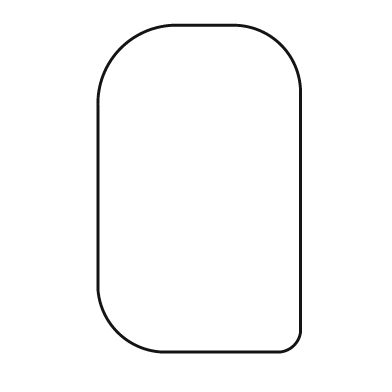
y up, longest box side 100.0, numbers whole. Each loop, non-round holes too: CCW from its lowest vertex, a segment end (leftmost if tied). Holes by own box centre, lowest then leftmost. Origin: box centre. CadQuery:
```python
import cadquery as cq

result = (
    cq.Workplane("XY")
    .moveTo(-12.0, -50.0)
    .lineTo(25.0, -50.0)
    .threePointArc((29.0, -48.0), (31.0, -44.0))
    .lineTo(31.0, 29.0)
    .threePointArc((25.0, 44.0), (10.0, 50.0))
    .lineTo(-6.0, 50.0)
    .threePointArc((-24.0, 43.0), (-31.0, 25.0))
    .lineTo(-31.0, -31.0)
    .threePointArc((-25.0, -44.0), (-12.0, -50.0))
    .close()
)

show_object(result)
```